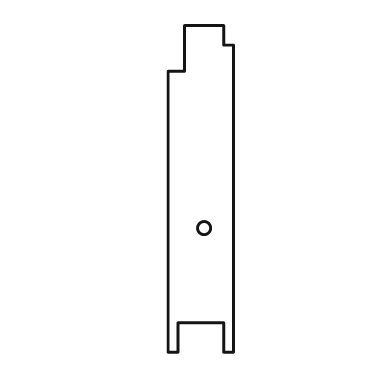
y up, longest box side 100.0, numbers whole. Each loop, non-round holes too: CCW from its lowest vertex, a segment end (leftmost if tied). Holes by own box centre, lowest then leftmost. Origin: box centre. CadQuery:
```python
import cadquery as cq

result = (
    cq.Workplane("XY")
    .moveTo(-10.0, -50.0)
    .lineTo(-7.0, -50.0)
    .lineTo(-7.0, -41.0)
    .lineTo(7.0, -41.0)
    .lineTo(7.0, -50.0)
    .lineTo(10.0, -50.0)
    .lineTo(10.0, 44.0)
    .lineTo(7.0, 44.0)
    .lineTo(7.0, 50.0)
    .lineTo(-5.0, 50.0)
    .lineTo(-5.0, 36.0)
    .lineTo(-10.0, 36.0)
    .close()
    .moveTo(1.0, -12.0)
    .circle(2.0)
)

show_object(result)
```